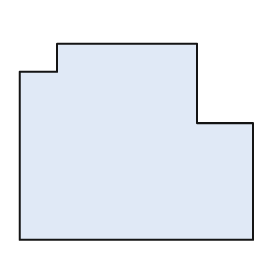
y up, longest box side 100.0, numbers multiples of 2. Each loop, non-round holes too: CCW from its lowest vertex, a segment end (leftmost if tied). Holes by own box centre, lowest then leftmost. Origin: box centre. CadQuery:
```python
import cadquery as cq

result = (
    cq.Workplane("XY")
    .moveTo(-50.0, -42.0)
    .lineTo(50.0, -42.0)
    .lineTo(50.0, 8.0)
    .lineTo(26.0, 8.0)
    .lineTo(26.0, 42.0)
    .lineTo(-34.0, 42.0)
    .lineTo(-34.0, 30.0)
    .lineTo(-50.0, 30.0)
    .close()
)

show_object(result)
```